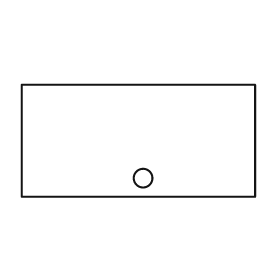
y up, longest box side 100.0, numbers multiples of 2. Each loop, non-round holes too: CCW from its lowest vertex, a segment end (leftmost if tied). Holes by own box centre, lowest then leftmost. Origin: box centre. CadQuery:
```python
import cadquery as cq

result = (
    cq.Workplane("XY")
    .moveTo(-50.0, -24.0)
    .lineTo(50.0, -24.0)
    .lineTo(50.0, 24.0)
    .lineTo(-50.0, 24.0)
    .close()
    .moveTo(2.0, -16.0)
    .circle(4.0)
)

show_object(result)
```